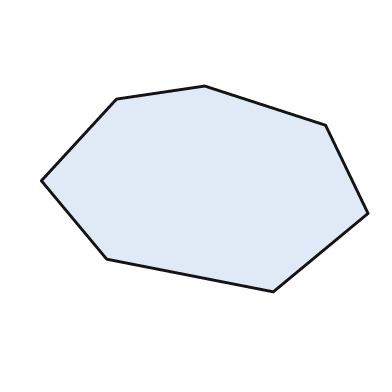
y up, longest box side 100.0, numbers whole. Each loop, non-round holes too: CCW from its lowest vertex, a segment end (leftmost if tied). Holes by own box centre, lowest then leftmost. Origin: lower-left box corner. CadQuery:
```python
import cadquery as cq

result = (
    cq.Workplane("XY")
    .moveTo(71.0, 0.0)
    .lineTo(100.0, 24.0)
    .lineTo(87.0, 51.0)
    .lineTo(50.0, 63.0)
    .lineTo(23.0, 59.0)
    .lineTo(0.0, 34.0)
    .lineTo(20.0, 10.0)
    .close()
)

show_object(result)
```